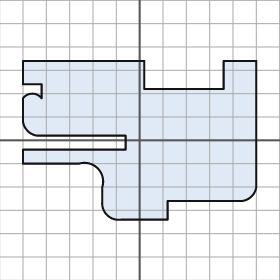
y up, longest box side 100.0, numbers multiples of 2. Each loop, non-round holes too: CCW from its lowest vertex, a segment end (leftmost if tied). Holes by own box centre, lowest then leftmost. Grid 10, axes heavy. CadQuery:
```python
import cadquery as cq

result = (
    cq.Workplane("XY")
    .moveTo(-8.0, -34.0)
    .lineTo(12.0, -34.0)
    .lineTo(12.0, -26.0)
    .lineTo(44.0, -26.0)
    .threePointArc((48.0, -24.0), (50.0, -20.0))
    .lineTo(50.0, 34.0)
    .lineTo(36.0, 34.0)
    .lineTo(36.0, 22.0)
    .lineTo(2.0, 22.0)
    .lineTo(2.0, 34.0)
    .lineTo(-50.0, 34.0)
    .lineTo(-50.0, 24.0)
    .lineTo(-42.0, 24.0)
    .lineTo(-42.0, 18.0)
    .threePointArc((-46.0, 20.0), (-50.0, 18.0))
    .lineTo(-50.0, 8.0)
    .threePointArc((-48.0, 4.0), (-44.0, 2.0))
    .lineTo(-6.0, 2.0)
    .lineTo(-6.0, -4.0)
    .lineTo(-50.0, -4.0)
    .lineTo(-50.0, -10.0)
    .lineTo(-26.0, -10.0)
    .threePointArc((-18.0, -12.0), (-16.0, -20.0))
    .lineTo(-16.0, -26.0)
    .threePointArc((-14.0, -32.0), (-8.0, -34.0))
    .close()
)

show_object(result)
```